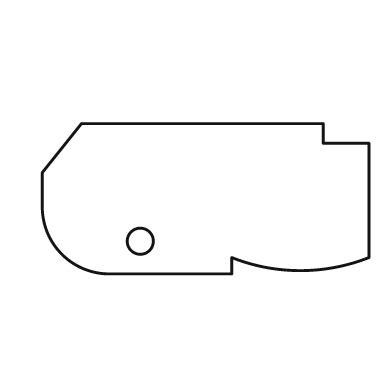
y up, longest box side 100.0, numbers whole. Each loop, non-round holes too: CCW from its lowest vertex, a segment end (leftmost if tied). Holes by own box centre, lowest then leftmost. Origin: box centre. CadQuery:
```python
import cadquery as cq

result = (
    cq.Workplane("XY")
    .moveTo(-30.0, -23.0)
    .lineTo(8.0, -23.0)
    .lineTo(8.0, -18.0)
    .threePointArc((29.0, -22.0), (50.0, -18.0))
    .lineTo(50.0, 17.0)
    .lineTo(36.0, 17.0)
    .lineTo(36.0, 23.0)
    .lineTo(-38.0, 23.0)
    .lineTo(-50.0, 8.0)
    .lineTo(-50.0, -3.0)
    .threePointArc((-44.0, -17.0), (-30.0, -23.0))
    .close()
    .moveTo(-20.0, -13.0)
    .circle(4.0)
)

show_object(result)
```